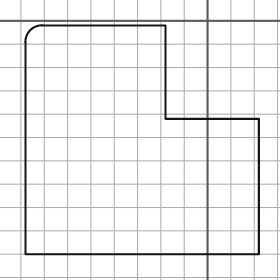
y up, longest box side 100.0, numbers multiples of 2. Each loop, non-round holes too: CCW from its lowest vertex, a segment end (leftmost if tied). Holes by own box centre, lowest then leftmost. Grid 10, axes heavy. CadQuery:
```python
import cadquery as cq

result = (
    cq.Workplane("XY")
    .moveTo(-78.0, -100.0)
    .lineTo(22.0, -100.0)
    .lineTo(22.0, -42.0)
    .lineTo(-18.0, -42.0)
    .lineTo(-18.0, -2.0)
    .lineTo(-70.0, -2.0)
    .threePointArc((-76.0, -4.0), (-78.0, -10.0))
    .close()
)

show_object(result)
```